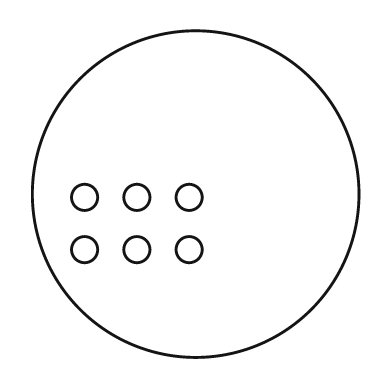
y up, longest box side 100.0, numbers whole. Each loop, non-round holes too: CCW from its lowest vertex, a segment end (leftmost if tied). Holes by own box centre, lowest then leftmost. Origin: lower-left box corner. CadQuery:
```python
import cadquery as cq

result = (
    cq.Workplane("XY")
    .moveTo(50.0, 50.0)
    .circle(50.0)
    .moveTo(16.0, 33.0)
    .circle(4.0)
    .moveTo(32.0, 33.0)
    .circle(4.0)
    .moveTo(48.0, 33.0)
    .circle(4.0)
    .moveTo(16.0, 49.0)
    .circle(4.0)
    .moveTo(32.0, 49.0)
    .circle(4.0)
    .moveTo(48.0, 49.0)
    .circle(4.0)
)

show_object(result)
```